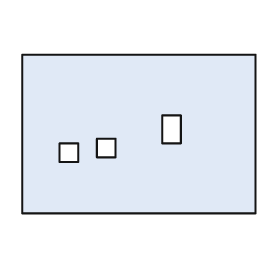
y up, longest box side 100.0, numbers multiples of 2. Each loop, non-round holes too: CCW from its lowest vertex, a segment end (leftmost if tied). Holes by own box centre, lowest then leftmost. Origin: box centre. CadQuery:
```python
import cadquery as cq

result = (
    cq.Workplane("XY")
    .moveTo(-50.0, -34.0)
    .lineTo(50.0, -34.0)
    .lineTo(50.0, 34.0)
    .lineTo(-50.0, 34.0)
    .close()
    .moveTo(-34.0, -12.0)
    .lineTo(-26.0, -12.0)
    .lineTo(-26.0, -4.0)
    .lineTo(-34.0, -4.0)
    .close()
    .moveTo(-18.0, -10.0)
    .lineTo(-10.0, -10.0)
    .lineTo(-10.0, -2.0)
    .lineTo(-18.0, -2.0)
    .close()
    .moveTo(10.0, -4.0)
    .lineTo(18.0, -4.0)
    .lineTo(18.0, 8.0)
    .lineTo(10.0, 8.0)
    .close()
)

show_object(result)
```